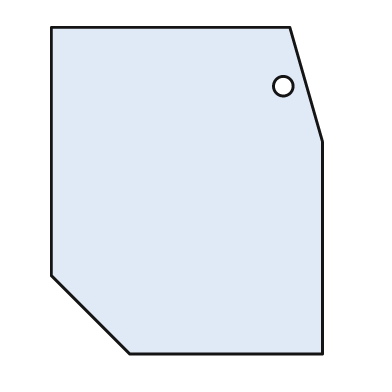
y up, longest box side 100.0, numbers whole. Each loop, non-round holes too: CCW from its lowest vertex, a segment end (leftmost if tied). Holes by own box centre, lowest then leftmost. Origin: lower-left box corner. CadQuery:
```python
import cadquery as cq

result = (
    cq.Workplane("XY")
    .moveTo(24.0, 0.0)
    .lineTo(83.0, 0.0)
    .lineTo(83.0, 65.0)
    .lineTo(73.0, 100.0)
    .lineTo(0.0, 100.0)
    .lineTo(0.0, 24.0)
    .close()
    .moveTo(71.0, 82.0)
    .circle(3.0)
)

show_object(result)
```